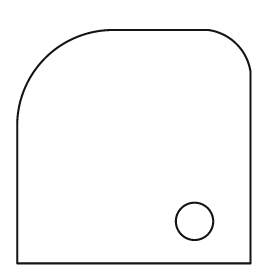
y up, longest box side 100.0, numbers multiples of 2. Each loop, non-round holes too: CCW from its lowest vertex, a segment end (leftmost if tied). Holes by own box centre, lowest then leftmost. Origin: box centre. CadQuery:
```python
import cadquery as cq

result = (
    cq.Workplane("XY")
    .moveTo(-50.0, -50.0)
    .lineTo(50.0, -50.0)
    .lineTo(50.0, 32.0)
    .threePointArc((44.0, 44.0), (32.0, 50.0))
    .lineTo(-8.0, 50.0)
    .threePointArc((-38.0, 38.0), (-50.0, 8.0))
    .close()
    .moveTo(26.0, -32.0)
    .circle(8.0)
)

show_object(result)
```